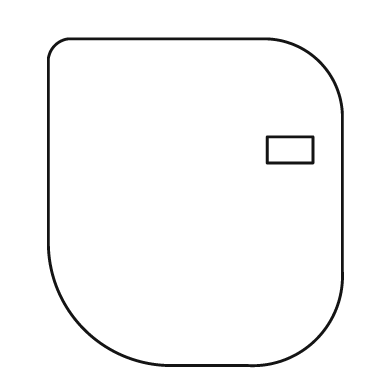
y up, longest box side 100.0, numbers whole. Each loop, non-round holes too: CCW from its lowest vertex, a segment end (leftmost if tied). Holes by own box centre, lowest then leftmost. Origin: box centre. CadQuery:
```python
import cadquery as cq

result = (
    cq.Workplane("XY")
    .moveTo(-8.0, -50.0)
    .lineTo(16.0, -50.0)
    .threePointArc((37.0, -42.0), (45.0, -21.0))
    .lineTo(45.0, 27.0)
    .threePointArc((38.0, 43.0), (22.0, 50.0))
    .lineTo(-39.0, 50.0)
    .threePointArc((-43.0, 48.0), (-45.0, 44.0))
    .lineTo(-45.0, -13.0)
    .threePointArc((-34.0, -39.0), (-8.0, -50.0))
    .close()
    .moveTo(22.0, 12.0)
    .lineTo(36.0, 12.0)
    .lineTo(36.0, 20.0)
    .lineTo(22.0, 20.0)
    .close()
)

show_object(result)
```